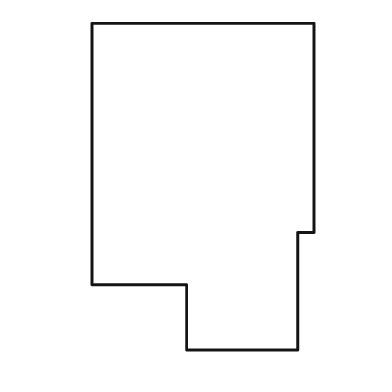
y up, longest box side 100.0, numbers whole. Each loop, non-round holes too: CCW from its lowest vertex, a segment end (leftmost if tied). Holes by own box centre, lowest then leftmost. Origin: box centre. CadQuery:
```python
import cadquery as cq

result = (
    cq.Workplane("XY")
    .moveTo(-5.0, -50.0)
    .lineTo(29.0, -50.0)
    .lineTo(29.0, -14.0)
    .lineTo(34.0, -14.0)
    .lineTo(34.0, 50.0)
    .lineTo(-34.0, 50.0)
    .lineTo(-34.0, -30.0)
    .lineTo(-5.0, -30.0)
    .close()
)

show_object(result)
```